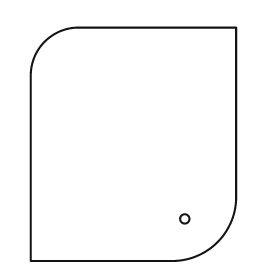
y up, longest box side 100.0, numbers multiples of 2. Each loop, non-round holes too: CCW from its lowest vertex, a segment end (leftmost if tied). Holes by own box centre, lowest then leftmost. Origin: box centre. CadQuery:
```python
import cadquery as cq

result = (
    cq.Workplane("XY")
    .moveTo(-44.0, -50.0)
    .lineTo(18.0, -50.0)
    .threePointArc((36.0, -42.0), (44.0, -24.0))
    .lineTo(44.0, 50.0)
    .lineTo(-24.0, 50.0)
    .threePointArc((-38.0, 44.0), (-44.0, 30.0))
    .close()
    .moveTo(22.0, -32.0)
    .circle(2.0)
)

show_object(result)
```